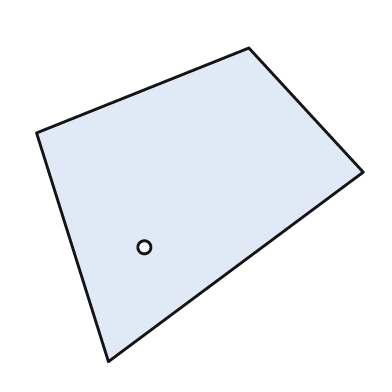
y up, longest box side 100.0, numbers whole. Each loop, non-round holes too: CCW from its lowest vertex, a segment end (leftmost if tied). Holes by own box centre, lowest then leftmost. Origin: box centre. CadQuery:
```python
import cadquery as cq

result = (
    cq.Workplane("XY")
    .moveTo(-28.0, -48.0)
    .lineTo(50.0, 10.0)
    .lineTo(15.0, 48.0)
    .lineTo(-50.0, 22.0)
    .close()
    .moveTo(-17.0, -13.0)
    .circle(2.0)
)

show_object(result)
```